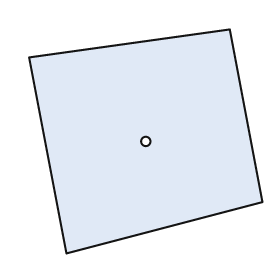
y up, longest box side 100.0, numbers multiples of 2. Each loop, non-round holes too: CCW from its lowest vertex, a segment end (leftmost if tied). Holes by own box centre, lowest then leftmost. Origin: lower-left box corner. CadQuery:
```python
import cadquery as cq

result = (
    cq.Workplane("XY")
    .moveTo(16.0, 0.0)
    .lineTo(100.0, 22.0)
    .lineTo(86.0, 96.0)
    .lineTo(0.0, 84.0)
    .close()
    .moveTo(50.0, 48.0)
    .circle(2.0)
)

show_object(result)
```